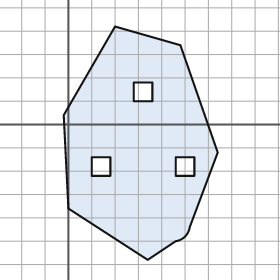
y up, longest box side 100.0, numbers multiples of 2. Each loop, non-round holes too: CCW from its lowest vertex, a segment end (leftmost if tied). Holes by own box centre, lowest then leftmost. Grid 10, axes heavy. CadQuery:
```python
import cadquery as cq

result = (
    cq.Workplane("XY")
    .moveTo(34.0, -58.0)
    .lineTo(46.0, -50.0)
    .threePointArc((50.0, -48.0), (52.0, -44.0))
    .lineTo(64.0, -12.0)
    .lineTo(48.0, 34.0)
    .lineTo(20.0, 42.0)
    .lineTo(-2.0, 4.0)
    .lineTo(0.0, -36.0)
    .close()
    .moveTo(10.0, -22.0)
    .lineTo(18.0, -22.0)
    .lineTo(18.0, -14.0)
    .lineTo(10.0, -14.0)
    .close()
    .moveTo(46.0, -22.0)
    .lineTo(54.0, -22.0)
    .lineTo(54.0, -14.0)
    .lineTo(46.0, -14.0)
    .close()
    .moveTo(28.0, 10.0)
    .lineTo(36.0, 10.0)
    .lineTo(36.0, 18.0)
    .lineTo(28.0, 18.0)
    .close()
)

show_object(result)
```